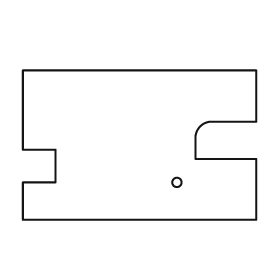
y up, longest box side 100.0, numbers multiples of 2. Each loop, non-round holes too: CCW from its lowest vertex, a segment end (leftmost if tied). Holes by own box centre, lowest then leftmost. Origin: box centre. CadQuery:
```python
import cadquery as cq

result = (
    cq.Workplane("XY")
    .moveTo(-50.0, -32.0)
    .lineTo(50.0, -32.0)
    .lineTo(50.0, -6.0)
    .lineTo(24.0, -6.0)
    .lineTo(24.0, 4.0)
    .threePointArc((26.0, 8.0), (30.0, 10.0))
    .lineTo(50.0, 10.0)
    .lineTo(50.0, 32.0)
    .lineTo(-50.0, 32.0)
    .lineTo(-50.0, -2.0)
    .lineTo(-36.0, -2.0)
    .lineTo(-36.0, -16.0)
    .lineTo(-50.0, -16.0)
    .close()
    .moveTo(16.0, -16.0)
    .circle(2.0)
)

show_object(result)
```